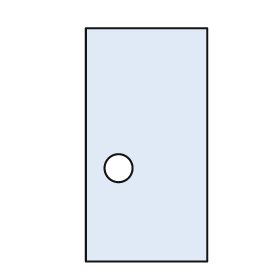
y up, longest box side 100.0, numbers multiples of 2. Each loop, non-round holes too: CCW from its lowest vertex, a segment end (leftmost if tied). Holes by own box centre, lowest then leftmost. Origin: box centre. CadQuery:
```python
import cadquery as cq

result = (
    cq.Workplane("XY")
    .moveTo(-26.0, -50.0)
    .lineTo(26.0, -50.0)
    .lineTo(26.0, 50.0)
    .lineTo(-26.0, 50.0)
    .close()
    .moveTo(-12.0, -10.0)
    .circle(6.0)
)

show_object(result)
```